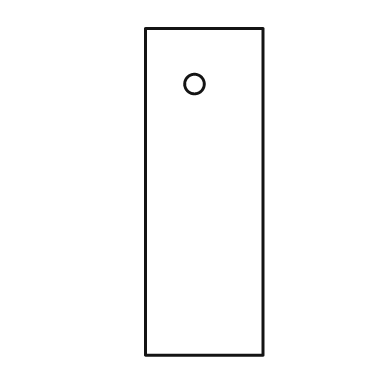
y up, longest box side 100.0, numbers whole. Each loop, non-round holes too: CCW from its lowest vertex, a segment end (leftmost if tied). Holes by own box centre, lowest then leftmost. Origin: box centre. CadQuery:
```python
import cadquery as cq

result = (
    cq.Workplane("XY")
    .moveTo(-18.0, -50.0)
    .lineTo(18.0, -50.0)
    .lineTo(18.0, 50.0)
    .lineTo(-18.0, 50.0)
    .close()
    .moveTo(-3.0, 33.0)
    .circle(3.0)
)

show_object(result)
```